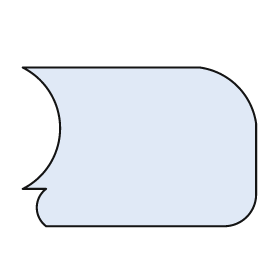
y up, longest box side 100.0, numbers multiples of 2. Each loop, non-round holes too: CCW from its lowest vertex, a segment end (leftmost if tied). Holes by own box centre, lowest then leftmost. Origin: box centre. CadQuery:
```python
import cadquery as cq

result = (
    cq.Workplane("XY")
    .moveTo(-40.0, -34.0)
    .lineTo(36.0, -34.0)
    .threePointArc((46.0, -30.0), (50.0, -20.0))
    .lineTo(50.0, 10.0)
    .threePointArc((42.0, 26.0), (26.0, 34.0))
    .lineTo(-50.0, 34.0)
    .threePointArc((-34.0, 8.0), (-50.0, -18.0))
    .lineTo(-40.0, -18.0)
    .threePointArc((-44.0, -26.0), (-40.0, -34.0))
    .close()
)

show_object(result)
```